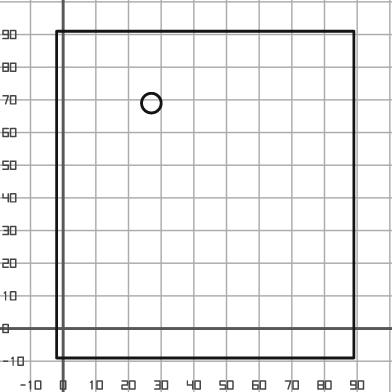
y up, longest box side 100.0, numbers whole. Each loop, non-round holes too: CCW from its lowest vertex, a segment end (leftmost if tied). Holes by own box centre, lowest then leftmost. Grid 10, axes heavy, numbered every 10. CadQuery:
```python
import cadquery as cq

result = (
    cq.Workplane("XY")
    .moveTo(-2.0, -9.0)
    .lineTo(89.0, -9.0)
    .lineTo(89.0, 91.0)
    .lineTo(-2.0, 91.0)
    .close()
    .moveTo(27.0, 69.0)
    .circle(3.0)
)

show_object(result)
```